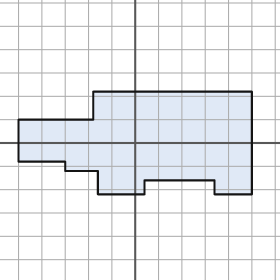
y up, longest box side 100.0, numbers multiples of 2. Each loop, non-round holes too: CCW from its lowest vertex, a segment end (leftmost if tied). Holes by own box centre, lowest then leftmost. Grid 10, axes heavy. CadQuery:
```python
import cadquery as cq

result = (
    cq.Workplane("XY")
    .moveTo(-16.0, -22.0)
    .lineTo(4.0, -22.0)
    .lineTo(4.0, -16.0)
    .lineTo(34.0, -16.0)
    .lineTo(34.0, -22.0)
    .lineTo(50.0, -22.0)
    .lineTo(50.0, 22.0)
    .lineTo(-18.0, 22.0)
    .lineTo(-18.0, 10.0)
    .lineTo(-50.0, 10.0)
    .lineTo(-50.0, -8.0)
    .lineTo(-30.0, -8.0)
    .lineTo(-30.0, -12.0)
    .lineTo(-16.0, -12.0)
    .close()
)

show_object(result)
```